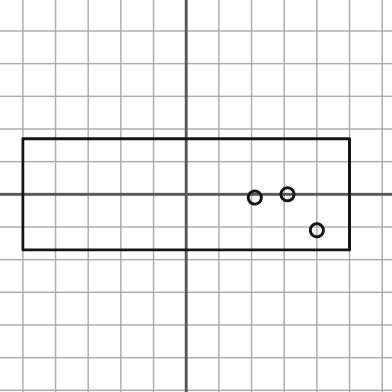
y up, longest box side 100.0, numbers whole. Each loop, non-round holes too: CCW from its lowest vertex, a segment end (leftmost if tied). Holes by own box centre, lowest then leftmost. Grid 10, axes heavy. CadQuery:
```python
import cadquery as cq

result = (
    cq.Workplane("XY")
    .moveTo(-50.0, -17.0)
    .lineTo(50.0, -17.0)
    .lineTo(50.0, 17.0)
    .lineTo(-50.0, 17.0)
    .close()
    .moveTo(40.0, -11.0)
    .circle(2.0)
    .moveTo(21.0, -1.0)
    .circle(2.0)
    .moveTo(31.0, 0.0)
    .circle(2.0)
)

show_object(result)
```